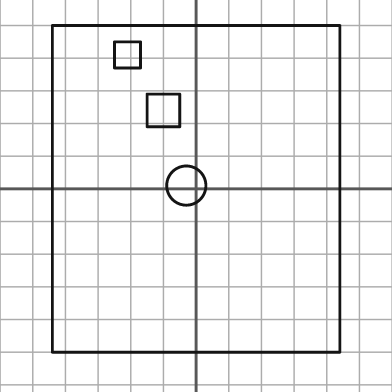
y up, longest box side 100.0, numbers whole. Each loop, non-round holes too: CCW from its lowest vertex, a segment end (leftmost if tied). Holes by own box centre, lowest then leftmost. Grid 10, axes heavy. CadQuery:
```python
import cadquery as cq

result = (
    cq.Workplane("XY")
    .moveTo(-44.0, -50.0)
    .lineTo(44.0, -50.0)
    .lineTo(44.0, 50.0)
    .lineTo(-44.0, 50.0)
    .close()
    .moveTo(-3.0, 1.0)
    .circle(6.0)
    .moveTo(-15.0, 19.0)
    .lineTo(-5.0, 19.0)
    .lineTo(-5.0, 29.0)
    .lineTo(-15.0, 29.0)
    .close()
    .moveTo(-25.0, 37.0)
    .lineTo(-17.0, 37.0)
    .lineTo(-17.0, 45.0)
    .lineTo(-25.0, 45.0)
    .close()
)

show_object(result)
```